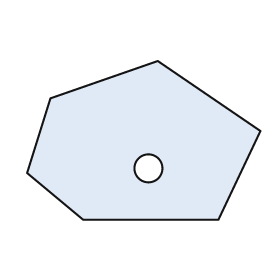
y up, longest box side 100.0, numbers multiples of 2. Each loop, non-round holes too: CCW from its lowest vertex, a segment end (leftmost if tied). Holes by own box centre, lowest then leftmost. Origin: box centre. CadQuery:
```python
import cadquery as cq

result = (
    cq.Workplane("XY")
    .moveTo(-26.0, -34.0)
    .lineTo(32.0, -34.0)
    .lineTo(50.0, 4.0)
    .lineTo(6.0, 34.0)
    .lineTo(-40.0, 18.0)
    .lineTo(-50.0, -14.0)
    .close()
    .moveTo(2.0, -12.0)
    .circle(6.0)
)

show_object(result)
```